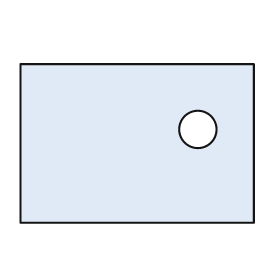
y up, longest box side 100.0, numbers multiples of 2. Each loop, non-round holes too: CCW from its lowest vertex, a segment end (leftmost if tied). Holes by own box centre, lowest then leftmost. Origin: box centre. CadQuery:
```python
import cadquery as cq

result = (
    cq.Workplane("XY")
    .moveTo(-50.0, -34.0)
    .lineTo(50.0, -34.0)
    .lineTo(50.0, 34.0)
    .lineTo(-50.0, 34.0)
    .close()
    .moveTo(26.0, 6.0)
    .circle(8.0)
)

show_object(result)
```